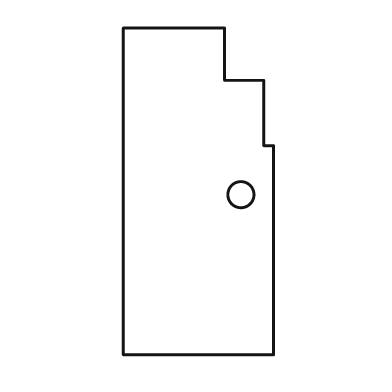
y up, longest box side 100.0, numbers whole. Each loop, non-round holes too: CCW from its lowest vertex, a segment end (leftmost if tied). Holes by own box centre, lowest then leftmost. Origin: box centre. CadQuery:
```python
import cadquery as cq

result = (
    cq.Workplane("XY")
    .moveTo(-23.0, -50.0)
    .lineTo(23.0, -50.0)
    .lineTo(23.0, 14.0)
    .lineTo(20.0, 14.0)
    .lineTo(20.0, 34.0)
    .lineTo(8.0, 34.0)
    .lineTo(8.0, 50.0)
    .lineTo(-23.0, 50.0)
    .close()
    .moveTo(13.0, -1.0)
    .circle(4.0)
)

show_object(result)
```